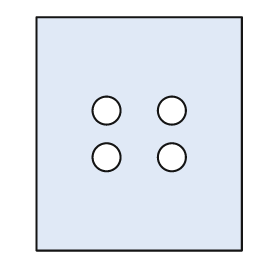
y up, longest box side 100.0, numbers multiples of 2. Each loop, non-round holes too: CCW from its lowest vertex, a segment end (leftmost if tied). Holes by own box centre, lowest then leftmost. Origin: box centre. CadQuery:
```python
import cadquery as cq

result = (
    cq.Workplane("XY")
    .moveTo(-44.0, -50.0)
    .lineTo(44.0, -50.0)
    .lineTo(44.0, 50.0)
    .lineTo(-44.0, 50.0)
    .close()
    .moveTo(-14.0, -10.0)
    .circle(6.0)
    .moveTo(14.0, -10.0)
    .circle(6.0)
    .moveTo(-14.0, 10.0)
    .circle(6.0)
    .moveTo(14.0, 10.0)
    .circle(6.0)
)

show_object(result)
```